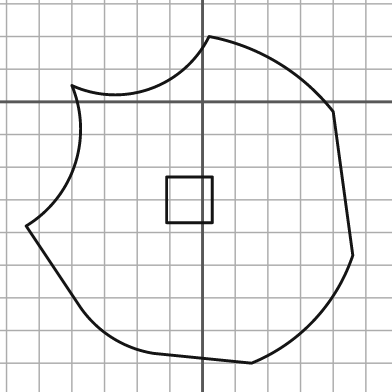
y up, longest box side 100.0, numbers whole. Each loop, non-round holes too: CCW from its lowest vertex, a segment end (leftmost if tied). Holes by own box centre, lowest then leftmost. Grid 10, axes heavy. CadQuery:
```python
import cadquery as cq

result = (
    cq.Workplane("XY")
    .moveTo(15.0, -80.0)
    .threePointArc((34.0, -67.0), (46.0, -47.0))
    .lineTo(40.0, -3.0)
    .threePointArc((23.0, 12.0), (2.0, 20.0))
    .threePointArc((-16.0, 4.0), (-40.0, 5.0))
    .threePointArc((-39.0, -19.0), (-54.0, -38.0))
    .lineTo(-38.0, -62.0)
    .threePointArc((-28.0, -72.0), (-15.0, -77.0))
    .close()
    .moveTo(-11.0, -37.0)
    .lineTo(3.0, -37.0)
    .lineTo(3.0, -23.0)
    .lineTo(-11.0, -23.0)
    .close()
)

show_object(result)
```